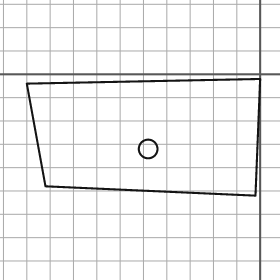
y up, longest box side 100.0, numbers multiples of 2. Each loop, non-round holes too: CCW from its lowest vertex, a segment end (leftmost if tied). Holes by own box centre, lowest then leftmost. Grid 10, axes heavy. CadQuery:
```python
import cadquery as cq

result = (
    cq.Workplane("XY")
    .moveTo(-2.0, -52.0)
    .lineTo(0.0, -2.0)
    .lineTo(-100.0, -4.0)
    .lineTo(-92.0, -48.0)
    .close()
    .moveTo(-48.0, -32.0)
    .circle(4.0)
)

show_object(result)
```